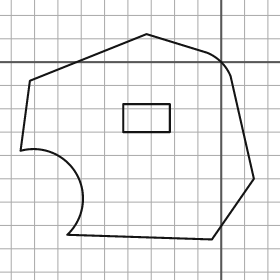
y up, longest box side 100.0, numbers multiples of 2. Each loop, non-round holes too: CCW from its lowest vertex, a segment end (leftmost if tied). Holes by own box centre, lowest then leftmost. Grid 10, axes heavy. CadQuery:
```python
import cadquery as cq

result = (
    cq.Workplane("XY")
    .moveTo(-4.0, -76.0)
    .lineTo(14.0, -50.0)
    .lineTo(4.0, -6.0)
    .threePointArc((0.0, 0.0), (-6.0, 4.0))
    .lineTo(-32.0, 12.0)
    .lineTo(-82.0, -8.0)
    .lineTo(-86.0, -38.0)
    .threePointArc((-62.0, -48.0), (-66.0, -74.0))
    .close()
    .moveTo(-42.0, -30.0)
    .lineTo(-22.0, -30.0)
    .lineTo(-22.0, -18.0)
    .lineTo(-42.0, -18.0)
    .close()
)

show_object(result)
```